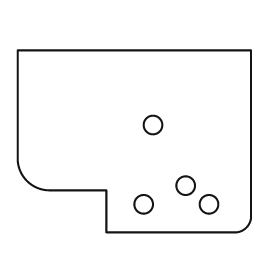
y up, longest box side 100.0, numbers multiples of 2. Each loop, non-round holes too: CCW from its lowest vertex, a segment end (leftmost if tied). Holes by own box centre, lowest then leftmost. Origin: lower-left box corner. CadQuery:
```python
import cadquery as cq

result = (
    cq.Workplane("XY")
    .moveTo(38.0, 0.0)
    .lineTo(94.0, 0.0)
    .threePointArc((98.0, 2.0), (100.0, 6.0))
    .lineTo(100.0, 78.0)
    .lineTo(0.0, 78.0)
    .lineTo(0.0, 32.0)
    .threePointArc((4.0, 22.0), (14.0, 18.0))
    .lineTo(38.0, 18.0)
    .close()
    .moveTo(54.0, 12.0)
    .circle(4.0)
    .moveTo(82.0, 12.0)
    .circle(4.0)
    .moveTo(72.0, 20.0)
    .circle(4.0)
    .moveTo(58.0, 46.0)
    .circle(4.0)
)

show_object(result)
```